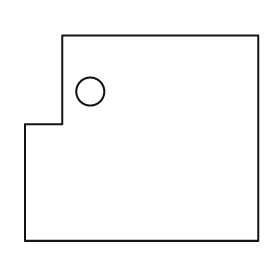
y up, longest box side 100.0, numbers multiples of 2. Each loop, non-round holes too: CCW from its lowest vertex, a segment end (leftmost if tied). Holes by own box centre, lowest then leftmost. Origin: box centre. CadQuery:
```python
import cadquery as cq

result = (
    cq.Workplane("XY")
    .moveTo(-50.0, -44.0)
    .lineTo(50.0, -44.0)
    .lineTo(50.0, 44.0)
    .lineTo(-34.0, 44.0)
    .lineTo(-34.0, 6.0)
    .lineTo(-50.0, 6.0)
    .close()
    .moveTo(-22.0, 20.0)
    .circle(6.0)
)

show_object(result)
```